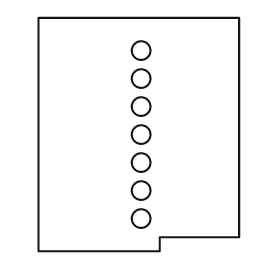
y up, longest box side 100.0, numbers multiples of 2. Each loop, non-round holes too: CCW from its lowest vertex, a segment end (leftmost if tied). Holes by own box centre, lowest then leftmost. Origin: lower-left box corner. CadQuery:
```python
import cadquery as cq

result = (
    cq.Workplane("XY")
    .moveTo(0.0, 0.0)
    .lineTo(52.0, 0.0)
    .lineTo(52.0, 6.0)
    .lineTo(86.0, 6.0)
    .lineTo(86.0, 100.0)
    .lineTo(0.0, 100.0)
    .close()
    .moveTo(44.0, 14.0)
    .circle(4.0)
    .moveTo(44.0, 26.0)
    .circle(4.0)
    .moveTo(44.0, 38.0)
    .circle(4.0)
    .moveTo(44.0, 50.0)
    .circle(4.0)
    .moveTo(44.0, 62.0)
    .circle(4.0)
    .moveTo(44.0, 74.0)
    .circle(4.0)
    .moveTo(44.0, 86.0)
    .circle(4.0)
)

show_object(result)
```